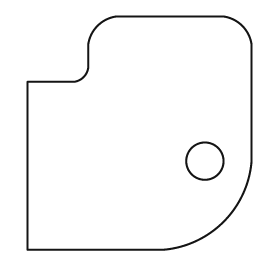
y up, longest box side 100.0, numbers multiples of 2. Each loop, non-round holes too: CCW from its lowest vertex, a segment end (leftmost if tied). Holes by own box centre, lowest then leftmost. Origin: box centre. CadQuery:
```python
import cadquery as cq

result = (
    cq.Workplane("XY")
    .moveTo(-48.0, -50.0)
    .lineTo(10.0, -50.0)
    .threePointArc((36.0, -38.0), (48.0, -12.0))
    .lineTo(48.0, 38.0)
    .threePointArc((44.0, 46.0), (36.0, 50.0))
    .lineTo(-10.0, 50.0)
    .threePointArc((-18.0, 46.0), (-22.0, 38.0))
    .lineTo(-22.0, 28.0)
    .threePointArc((-24.0, 24.0), (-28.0, 22.0))
    .lineTo(-48.0, 22.0)
    .close()
    .moveTo(28.0, -12.0)
    .circle(8.0)
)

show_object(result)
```